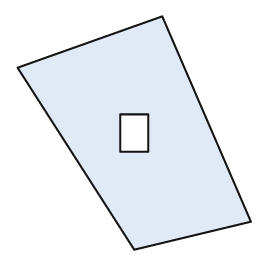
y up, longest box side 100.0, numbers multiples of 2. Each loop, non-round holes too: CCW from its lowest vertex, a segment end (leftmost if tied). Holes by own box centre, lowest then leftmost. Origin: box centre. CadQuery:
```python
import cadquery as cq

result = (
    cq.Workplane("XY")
    .moveTo(0.0, -50.0)
    .lineTo(50.0, -38.0)
    .lineTo(12.0, 50.0)
    .lineTo(-50.0, 28.0)
    .close()
    .moveTo(-6.0, -8.0)
    .lineTo(6.0, -8.0)
    .lineTo(6.0, 8.0)
    .lineTo(-6.0, 8.0)
    .close()
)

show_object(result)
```